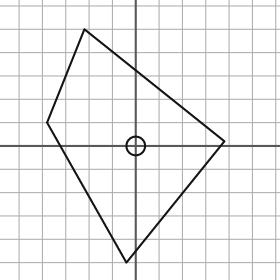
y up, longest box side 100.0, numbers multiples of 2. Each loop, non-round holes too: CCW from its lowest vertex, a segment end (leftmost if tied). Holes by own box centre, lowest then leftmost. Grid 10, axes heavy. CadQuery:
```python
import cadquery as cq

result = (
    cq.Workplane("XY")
    .moveTo(-4.0, -50.0)
    .lineTo(38.0, 2.0)
    .lineTo(-22.0, 50.0)
    .lineTo(-38.0, 10.0)
    .close()
    .moveTo(0.0, 0.0)
    .circle(4.0)
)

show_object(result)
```